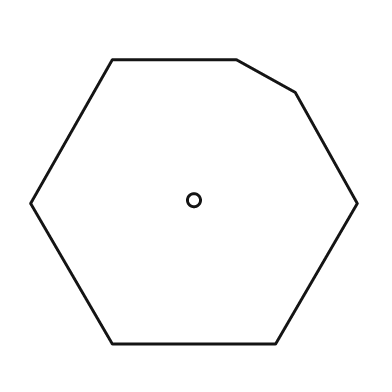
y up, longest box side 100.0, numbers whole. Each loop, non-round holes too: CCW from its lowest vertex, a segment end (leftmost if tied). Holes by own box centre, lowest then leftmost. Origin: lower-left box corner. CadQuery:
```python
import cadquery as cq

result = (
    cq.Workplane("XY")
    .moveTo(25.0, 0.0)
    .lineTo(75.0, 0.0)
    .lineTo(100.0, 43.0)
    .lineTo(81.0, 77.0)
    .lineTo(63.0, 87.0)
    .lineTo(25.0, 87.0)
    .lineTo(0.0, 43.0)
    .close()
    .moveTo(50.0, 44.0)
    .circle(2.0)
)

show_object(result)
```